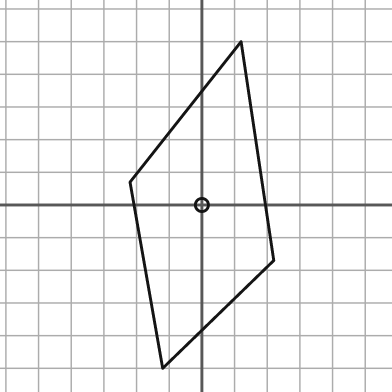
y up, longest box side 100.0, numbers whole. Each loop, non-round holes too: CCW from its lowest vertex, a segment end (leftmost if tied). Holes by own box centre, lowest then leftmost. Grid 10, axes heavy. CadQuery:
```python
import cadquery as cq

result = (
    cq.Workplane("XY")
    .moveTo(-12.0, -50.0)
    .lineTo(22.0, -17.0)
    .lineTo(12.0, 50.0)
    .lineTo(-22.0, 7.0)
    .close()
    .moveTo(0.0, 0.0)
    .circle(2.0)
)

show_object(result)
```